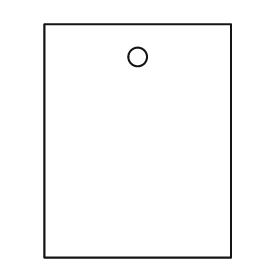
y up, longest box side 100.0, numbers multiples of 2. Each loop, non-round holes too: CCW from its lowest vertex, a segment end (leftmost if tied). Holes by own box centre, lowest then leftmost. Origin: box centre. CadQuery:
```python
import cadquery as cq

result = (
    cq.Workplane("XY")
    .moveTo(-40.0, -50.0)
    .lineTo(40.0, -50.0)
    .lineTo(40.0, 50.0)
    .lineTo(-40.0, 50.0)
    .close()
    .moveTo(0.0, 36.0)
    .circle(4.0)
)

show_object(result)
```